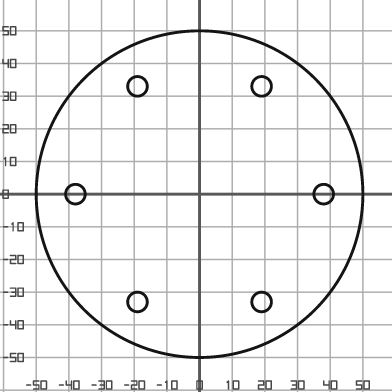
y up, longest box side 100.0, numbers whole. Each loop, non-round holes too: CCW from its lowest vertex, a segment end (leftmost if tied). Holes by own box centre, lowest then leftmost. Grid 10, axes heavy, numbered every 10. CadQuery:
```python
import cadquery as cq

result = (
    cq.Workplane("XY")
    .moveTo(0.0, 0.0)
    .circle(50.0)
    .moveTo(-19.0, -33.0)
    .circle(3.0)
    .moveTo(19.0, -33.0)
    .circle(3.0)
    .moveTo(-38.0, 0.0)
    .circle(3.0)
    .moveTo(38.0, 0.0)
    .circle(3.0)
    .moveTo(-19.0, 33.0)
    .circle(3.0)
    .moveTo(19.0, 33.0)
    .circle(3.0)
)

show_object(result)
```